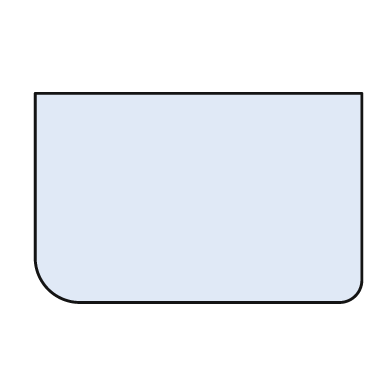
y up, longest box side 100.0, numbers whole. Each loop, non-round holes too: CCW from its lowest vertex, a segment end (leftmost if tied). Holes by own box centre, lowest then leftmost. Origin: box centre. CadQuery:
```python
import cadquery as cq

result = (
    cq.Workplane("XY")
    .moveTo(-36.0, -32.0)
    .lineTo(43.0, -32.0)
    .threePointArc((48.0, -30.0), (50.0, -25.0))
    .lineTo(50.0, 32.0)
    .lineTo(-50.0, 32.0)
    .lineTo(-50.0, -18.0)
    .threePointArc((-46.0, -28.0), (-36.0, -32.0))
    .close()
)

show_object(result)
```